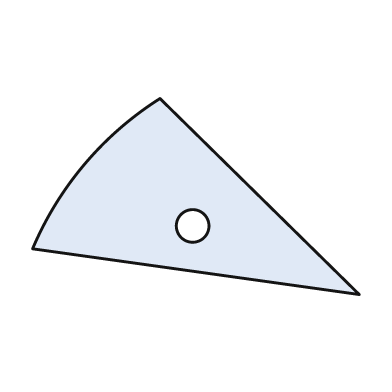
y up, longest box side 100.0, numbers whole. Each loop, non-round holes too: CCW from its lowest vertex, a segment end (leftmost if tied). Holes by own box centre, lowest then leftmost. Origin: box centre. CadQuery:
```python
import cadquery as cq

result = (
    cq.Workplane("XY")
    .moveTo(50.0, -30.0)
    .lineTo(-11.0, 30.0)
    .threePointArc((-34.0, 10.0), (-50.0, -16.0))
    .close()
    .moveTo(-1.0, -9.0)
    .circle(5.0)
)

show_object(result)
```